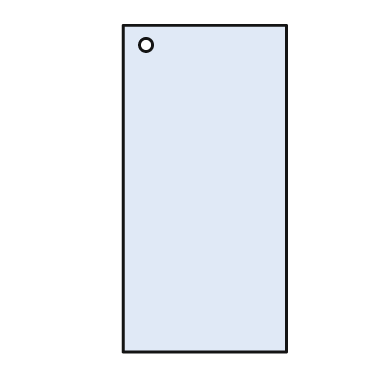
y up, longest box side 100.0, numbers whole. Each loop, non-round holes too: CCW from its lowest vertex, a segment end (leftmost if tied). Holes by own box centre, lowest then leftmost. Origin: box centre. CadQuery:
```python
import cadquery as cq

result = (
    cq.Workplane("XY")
    .moveTo(-25.0, -50.0)
    .lineTo(25.0, -50.0)
    .lineTo(25.0, 50.0)
    .lineTo(-25.0, 50.0)
    .close()
    .moveTo(-18.0, 44.0)
    .circle(2.0)
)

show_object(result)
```